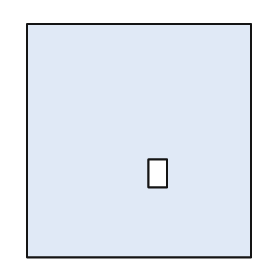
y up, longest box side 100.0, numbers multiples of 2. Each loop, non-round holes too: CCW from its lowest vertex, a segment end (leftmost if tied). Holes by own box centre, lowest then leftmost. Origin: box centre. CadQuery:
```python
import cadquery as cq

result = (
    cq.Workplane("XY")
    .moveTo(-48.0, -50.0)
    .lineTo(48.0, -50.0)
    .lineTo(48.0, 50.0)
    .lineTo(-48.0, 50.0)
    .close()
    .moveTo(4.0, -20.0)
    .lineTo(12.0, -20.0)
    .lineTo(12.0, -8.0)
    .lineTo(4.0, -8.0)
    .close()
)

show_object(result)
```